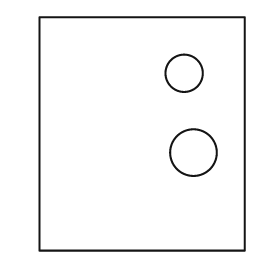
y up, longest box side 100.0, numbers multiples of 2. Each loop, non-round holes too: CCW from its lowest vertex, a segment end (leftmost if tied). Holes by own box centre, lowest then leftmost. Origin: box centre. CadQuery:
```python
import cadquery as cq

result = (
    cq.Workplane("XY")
    .moveTo(-44.0, -50.0)
    .lineTo(44.0, -50.0)
    .lineTo(44.0, 50.0)
    .lineTo(-44.0, 50.0)
    .close()
    .moveTo(22.0, -8.0)
    .circle(10.0)
    .moveTo(18.0, 26.0)
    .circle(8.0)
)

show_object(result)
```